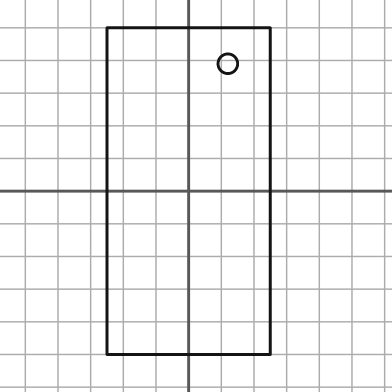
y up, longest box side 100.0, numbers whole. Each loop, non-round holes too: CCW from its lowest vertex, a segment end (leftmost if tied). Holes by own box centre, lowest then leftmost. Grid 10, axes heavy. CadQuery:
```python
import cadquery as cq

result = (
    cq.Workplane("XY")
    .moveTo(-25.0, -50.0)
    .lineTo(25.0, -50.0)
    .lineTo(25.0, 50.0)
    .lineTo(-25.0, 50.0)
    .close()
    .moveTo(12.0, 39.0)
    .circle(3.0)
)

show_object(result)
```